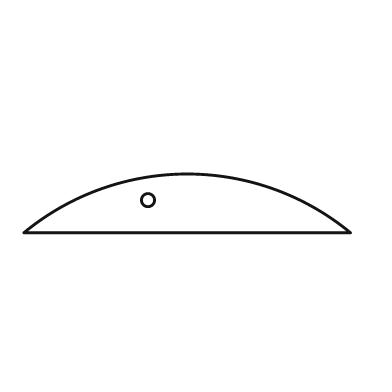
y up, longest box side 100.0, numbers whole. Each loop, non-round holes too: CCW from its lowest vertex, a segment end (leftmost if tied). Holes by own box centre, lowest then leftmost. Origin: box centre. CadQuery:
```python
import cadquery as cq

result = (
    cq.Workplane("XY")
    .moveTo(-50.0, -9.0)
    .lineTo(50.0, -9.0)
    .threePointArc((0.0, 9.0), (-50.0, -9.0))
    .close()
    .moveTo(-12.0, 1.0)
    .circle(2.0)
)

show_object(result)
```